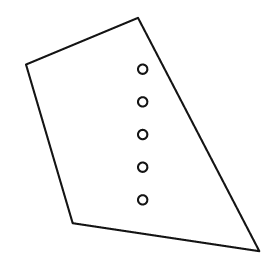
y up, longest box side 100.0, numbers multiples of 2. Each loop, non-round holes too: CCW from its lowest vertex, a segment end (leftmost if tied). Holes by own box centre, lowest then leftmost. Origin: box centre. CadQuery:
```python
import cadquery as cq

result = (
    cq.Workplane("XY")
    .moveTo(50.0, -50.0)
    .lineTo(-2.0, 50.0)
    .lineTo(-50.0, 30.0)
    .lineTo(-30.0, -38.0)
    .close()
    .moveTo(0.0, -28.0)
    .circle(2.0)
    .moveTo(0.0, -14.0)
    .circle(2.0)
    .moveTo(0.0, 0.0)
    .circle(2.0)
    .moveTo(0.0, 14.0)
    .circle(2.0)
    .moveTo(0.0, 28.0)
    .circle(2.0)
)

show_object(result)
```